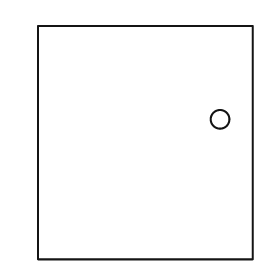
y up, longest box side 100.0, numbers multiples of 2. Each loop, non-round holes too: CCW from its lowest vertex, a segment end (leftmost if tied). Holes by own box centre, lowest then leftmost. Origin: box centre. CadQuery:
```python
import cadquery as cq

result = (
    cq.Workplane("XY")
    .moveTo(-46.0, -50.0)
    .lineTo(46.0, -50.0)
    .lineTo(46.0, 50.0)
    .lineTo(-46.0, 50.0)
    .close()
    .moveTo(32.0, 10.0)
    .circle(4.0)
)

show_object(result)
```